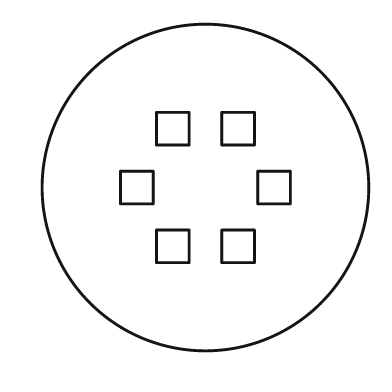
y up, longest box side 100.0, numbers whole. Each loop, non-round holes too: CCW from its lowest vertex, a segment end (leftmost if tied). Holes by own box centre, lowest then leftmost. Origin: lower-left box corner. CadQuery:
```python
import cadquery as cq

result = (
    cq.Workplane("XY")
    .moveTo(50.0, 50.0)
    .circle(50.0)
    .moveTo(35.0, 27.0)
    .lineTo(45.0, 27.0)
    .lineTo(45.0, 37.0)
    .lineTo(35.0, 37.0)
    .close()
    .moveTo(55.0, 27.0)
    .lineTo(65.0, 27.0)
    .lineTo(65.0, 37.0)
    .lineTo(55.0, 37.0)
    .close()
    .moveTo(24.0, 45.0)
    .lineTo(34.0, 45.0)
    .lineTo(34.0, 55.0)
    .lineTo(24.0, 55.0)
    .close()
    .moveTo(66.0, 45.0)
    .lineTo(76.0, 45.0)
    .lineTo(76.0, 55.0)
    .lineTo(66.0, 55.0)
    .close()
    .moveTo(35.0, 63.0)
    .lineTo(45.0, 63.0)
    .lineTo(45.0, 73.0)
    .lineTo(35.0, 73.0)
    .close()
    .moveTo(55.0, 63.0)
    .lineTo(65.0, 63.0)
    .lineTo(65.0, 73.0)
    .lineTo(55.0, 73.0)
    .close()
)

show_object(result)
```